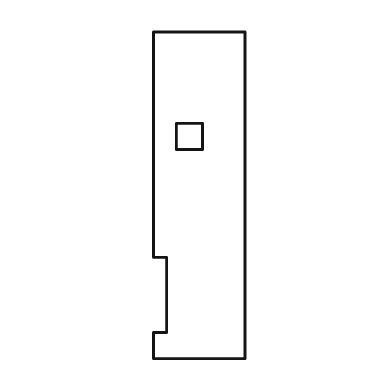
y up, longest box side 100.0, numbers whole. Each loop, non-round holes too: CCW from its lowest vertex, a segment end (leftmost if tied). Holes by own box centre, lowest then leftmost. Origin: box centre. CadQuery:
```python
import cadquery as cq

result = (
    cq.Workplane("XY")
    .moveTo(-14.0, -50.0)
    .lineTo(14.0, -50.0)
    .lineTo(14.0, 50.0)
    .lineTo(-14.0, 50.0)
    .lineTo(-14.0, -19.0)
    .lineTo(-10.0, -19.0)
    .lineTo(-10.0, -42.0)
    .lineTo(-14.0, -42.0)
    .close()
    .moveTo(-7.0, 14.0)
    .lineTo(1.0, 14.0)
    .lineTo(1.0, 22.0)
    .lineTo(-7.0, 22.0)
    .close()
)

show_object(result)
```